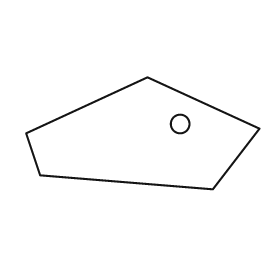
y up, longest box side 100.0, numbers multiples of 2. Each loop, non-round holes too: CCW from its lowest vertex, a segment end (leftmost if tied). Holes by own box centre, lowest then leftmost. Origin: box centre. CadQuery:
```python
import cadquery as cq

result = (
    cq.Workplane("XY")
    .moveTo(30.0, -24.0)
    .lineTo(50.0, 2.0)
    .lineTo(2.0, 24.0)
    .lineTo(-50.0, 0.0)
    .lineTo(-44.0, -18.0)
    .close()
    .moveTo(16.0, 4.0)
    .circle(4.0)
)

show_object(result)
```